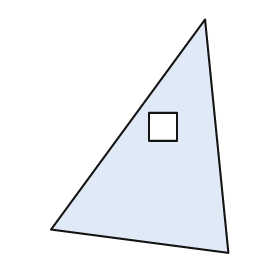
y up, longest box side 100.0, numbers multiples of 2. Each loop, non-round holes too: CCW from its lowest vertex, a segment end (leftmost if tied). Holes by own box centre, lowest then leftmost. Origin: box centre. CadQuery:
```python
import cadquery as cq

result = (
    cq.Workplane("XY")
    .moveTo(38.0, -50.0)
    .lineTo(28.0, 50.0)
    .lineTo(-38.0, -40.0)
    .close()
    .moveTo(4.0, -2.0)
    .lineTo(16.0, -2.0)
    .lineTo(16.0, 10.0)
    .lineTo(4.0, 10.0)
    .close()
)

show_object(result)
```